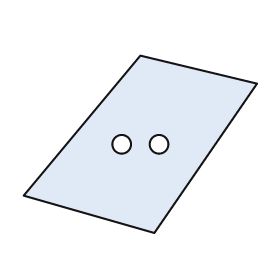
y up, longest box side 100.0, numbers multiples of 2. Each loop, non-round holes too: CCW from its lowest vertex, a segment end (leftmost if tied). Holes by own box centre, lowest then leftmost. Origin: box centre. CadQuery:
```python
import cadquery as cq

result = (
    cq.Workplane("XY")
    .moveTo(6.0, -38.0)
    .lineTo(50.0, 26.0)
    .lineTo(0.0, 38.0)
    .lineTo(-50.0, -22.0)
    .close()
    .moveTo(-8.0, 0.0)
    .circle(4.0)
    .moveTo(8.0, 0.0)
    .circle(4.0)
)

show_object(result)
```